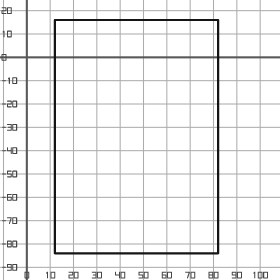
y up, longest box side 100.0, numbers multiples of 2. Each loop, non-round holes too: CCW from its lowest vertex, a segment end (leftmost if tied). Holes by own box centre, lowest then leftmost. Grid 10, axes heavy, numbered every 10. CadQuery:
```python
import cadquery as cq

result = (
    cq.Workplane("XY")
    .moveTo(12.0, -84.0)
    .lineTo(82.0, -84.0)
    .lineTo(82.0, 16.0)
    .lineTo(12.0, 16.0)
    .close()
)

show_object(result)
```